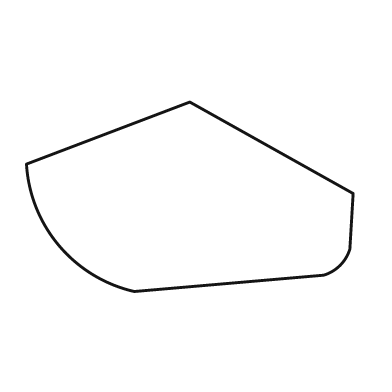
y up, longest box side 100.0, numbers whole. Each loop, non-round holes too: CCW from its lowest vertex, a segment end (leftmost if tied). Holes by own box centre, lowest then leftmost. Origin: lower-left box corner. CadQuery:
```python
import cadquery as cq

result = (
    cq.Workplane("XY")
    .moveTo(33.0, 0.0)
    .lineTo(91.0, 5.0)
    .threePointArc((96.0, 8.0), (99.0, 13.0))
    .lineTo(100.0, 30.0)
    .lineTo(50.0, 58.0)
    .lineTo(0.0, 39.0)
    .threePointArc((10.0, 14.0), (33.0, 0.0))
    .close()
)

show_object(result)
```